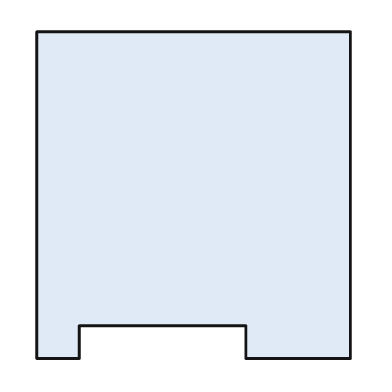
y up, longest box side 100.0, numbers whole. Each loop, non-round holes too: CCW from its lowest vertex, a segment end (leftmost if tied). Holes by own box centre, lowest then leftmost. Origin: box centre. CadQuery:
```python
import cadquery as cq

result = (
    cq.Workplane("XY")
    .moveTo(-48.0, -50.0)
    .lineTo(-35.0, -50.0)
    .lineTo(-35.0, -40.0)
    .lineTo(16.0, -40.0)
    .lineTo(16.0, -50.0)
    .lineTo(48.0, -50.0)
    .lineTo(48.0, 50.0)
    .lineTo(-48.0, 50.0)
    .close()
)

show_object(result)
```